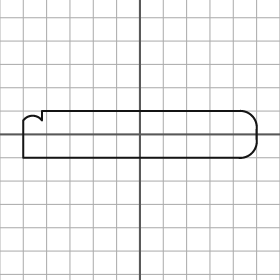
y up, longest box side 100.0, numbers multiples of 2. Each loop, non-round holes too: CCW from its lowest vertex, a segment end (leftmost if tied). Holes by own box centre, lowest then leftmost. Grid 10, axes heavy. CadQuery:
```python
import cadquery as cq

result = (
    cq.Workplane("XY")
    .moveTo(-50.0, -10.0)
    .lineTo(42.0, -10.0)
    .threePointArc((48.0, -8.0), (50.0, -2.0))
    .lineTo(50.0, 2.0)
    .threePointArc((48.0, 8.0), (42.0, 10.0))
    .lineTo(-42.0, 10.0)
    .lineTo(-42.0, 6.0)
    .threePointArc((-46.0, 8.0), (-50.0, 6.0))
    .close()
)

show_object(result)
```